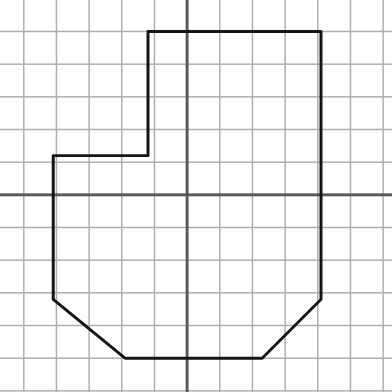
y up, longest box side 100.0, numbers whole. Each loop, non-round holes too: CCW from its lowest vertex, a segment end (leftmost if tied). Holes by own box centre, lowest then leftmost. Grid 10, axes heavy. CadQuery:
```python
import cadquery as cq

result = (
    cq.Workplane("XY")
    .moveTo(-19.0, -50.0)
    .lineTo(23.0, -50.0)
    .lineTo(41.0, -32.0)
    .lineTo(41.0, 50.0)
    .lineTo(-12.0, 50.0)
    .lineTo(-12.0, 12.0)
    .lineTo(-41.0, 12.0)
    .lineTo(-41.0, -32.0)
    .close()
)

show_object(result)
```